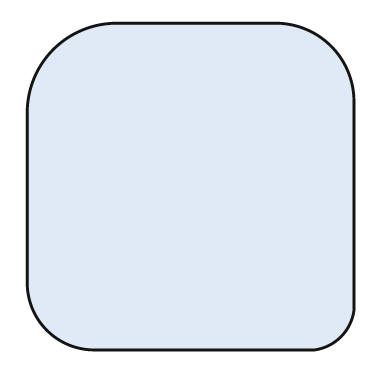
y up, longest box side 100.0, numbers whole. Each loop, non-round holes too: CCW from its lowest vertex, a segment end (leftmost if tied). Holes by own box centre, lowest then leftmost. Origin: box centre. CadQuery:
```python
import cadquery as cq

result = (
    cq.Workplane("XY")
    .moveTo(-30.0, -50.0)
    .lineTo(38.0, -50.0)
    .threePointArc((46.0, -46.0), (50.0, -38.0))
    .lineTo(50.0, 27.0)
    .threePointArc((43.0, 43.0), (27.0, 50.0))
    .lineTo(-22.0, 50.0)
    .threePointArc((-42.0, 42.0), (-50.0, 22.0))
    .lineTo(-50.0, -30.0)
    .threePointArc((-44.0, -44.0), (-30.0, -50.0))
    .close()
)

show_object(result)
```